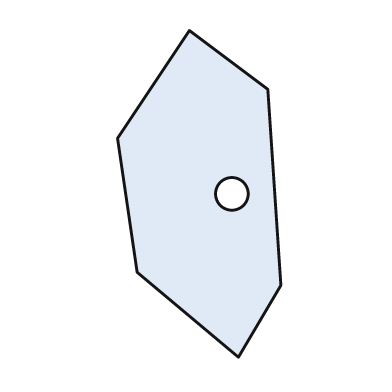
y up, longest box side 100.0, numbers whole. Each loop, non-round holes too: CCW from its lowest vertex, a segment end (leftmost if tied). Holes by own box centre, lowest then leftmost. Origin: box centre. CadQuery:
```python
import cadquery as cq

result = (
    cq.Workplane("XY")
    .moveTo(12.0, -50.0)
    .lineTo(25.0, -28.0)
    .lineTo(21.0, 32.0)
    .lineTo(-3.0, 50.0)
    .lineTo(-25.0, 17.0)
    .lineTo(-19.0, -24.0)
    .close()
    .moveTo(10.0, 0.0)
    .circle(5.0)
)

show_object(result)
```